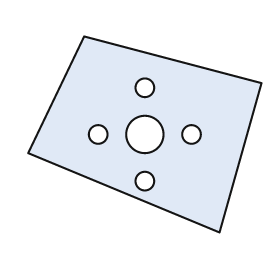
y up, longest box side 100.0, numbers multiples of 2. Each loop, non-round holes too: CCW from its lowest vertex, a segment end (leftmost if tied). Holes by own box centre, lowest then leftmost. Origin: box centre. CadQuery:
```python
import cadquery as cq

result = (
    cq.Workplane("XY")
    .moveTo(32.0, -42.0)
    .lineTo(50.0, 22.0)
    .lineTo(-26.0, 42.0)
    .lineTo(-50.0, -8.0)
    .close()
    .moveTo(0.0, -20.0)
    .circle(4.0)
    .moveTo(-20.0, 0.0)
    .circle(4.0)
    .moveTo(0.0, 0.0)
    .circle(8.0)
    .moveTo(20.0, 0.0)
    .circle(4.0)
    .moveTo(0.0, 20.0)
    .circle(4.0)
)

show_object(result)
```